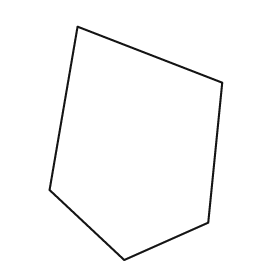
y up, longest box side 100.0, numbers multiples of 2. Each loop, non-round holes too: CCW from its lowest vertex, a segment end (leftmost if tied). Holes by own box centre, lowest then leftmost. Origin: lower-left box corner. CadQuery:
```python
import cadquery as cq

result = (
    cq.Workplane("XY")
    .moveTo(32.0, 0.0)
    .lineTo(68.0, 16.0)
    .lineTo(74.0, 76.0)
    .lineTo(12.0, 100.0)
    .lineTo(0.0, 30.0)
    .close()
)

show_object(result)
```